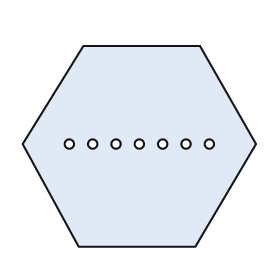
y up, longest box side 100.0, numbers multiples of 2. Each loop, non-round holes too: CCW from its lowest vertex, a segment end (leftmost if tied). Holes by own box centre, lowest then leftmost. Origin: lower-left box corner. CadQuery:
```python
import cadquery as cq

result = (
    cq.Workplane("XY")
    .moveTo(24.0, 0.0)
    .lineTo(74.0, 0.0)
    .lineTo(100.0, 44.0)
    .lineTo(76.0, 86.0)
    .lineTo(26.0, 86.0)
    .lineTo(0.0, 44.0)
    .close()
    .moveTo(20.0, 44.0)
    .circle(2.0)
    .moveTo(30.0, 44.0)
    .circle(2.0)
    .moveTo(40.0, 44.0)
    .circle(2.0)
    .moveTo(50.0, 44.0)
    .circle(2.0)
    .moveTo(60.0, 44.0)
    .circle(2.0)
    .moveTo(70.0, 44.0)
    .circle(2.0)
    .moveTo(80.0, 44.0)
    .circle(2.0)
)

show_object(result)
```